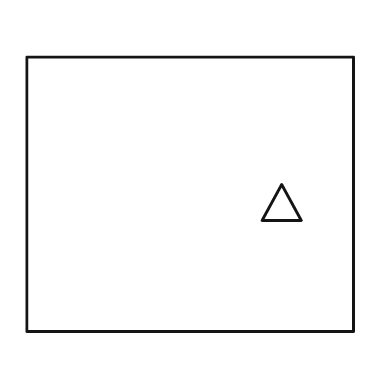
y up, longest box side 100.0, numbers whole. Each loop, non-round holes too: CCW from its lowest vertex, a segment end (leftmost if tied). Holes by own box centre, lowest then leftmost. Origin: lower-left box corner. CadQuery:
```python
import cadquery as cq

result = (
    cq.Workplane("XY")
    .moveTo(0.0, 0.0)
    .lineTo(100.0, 0.0)
    .lineTo(100.0, 84.0)
    .lineTo(0.0, 84.0)
    .close()
    .moveTo(72.0, 34.0)
    .lineTo(84.0, 34.0)
    .lineTo(78.0, 45.0)
    .close()
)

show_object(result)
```